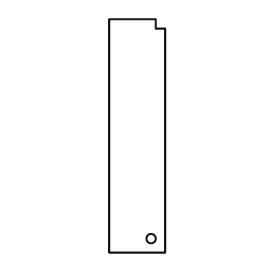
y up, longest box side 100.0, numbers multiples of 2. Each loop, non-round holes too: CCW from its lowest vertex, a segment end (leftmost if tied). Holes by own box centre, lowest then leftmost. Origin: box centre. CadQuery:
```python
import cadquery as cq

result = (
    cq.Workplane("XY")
    .moveTo(-12.0, -50.0)
    .lineTo(12.0, -50.0)
    .lineTo(12.0, 46.0)
    .lineTo(8.0, 46.0)
    .lineTo(8.0, 50.0)
    .lineTo(-12.0, 50.0)
    .close()
    .moveTo(6.0, -44.0)
    .circle(2.0)
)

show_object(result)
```